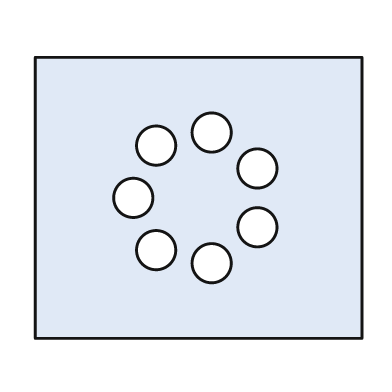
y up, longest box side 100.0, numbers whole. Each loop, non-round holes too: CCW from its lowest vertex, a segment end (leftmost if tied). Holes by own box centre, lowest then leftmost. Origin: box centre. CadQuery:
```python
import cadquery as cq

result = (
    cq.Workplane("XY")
    .moveTo(-50.0, -43.0)
    .lineTo(50.0, -43.0)
    .lineTo(50.0, 43.0)
    .lineTo(-50.0, 43.0)
    .close()
    .moveTo(4.0, -20.0)
    .circle(6.0)
    .moveTo(-13.0, -16.0)
    .circle(6.0)
    .moveTo(18.0, -9.0)
    .circle(6.0)
    .moveTo(-20.0, 0.0)
    .circle(6.0)
    .moveTo(18.0, 9.0)
    .circle(6.0)
    .moveTo(-13.0, 16.0)
    .circle(6.0)
    .moveTo(4.0, 20.0)
    .circle(6.0)
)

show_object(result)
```